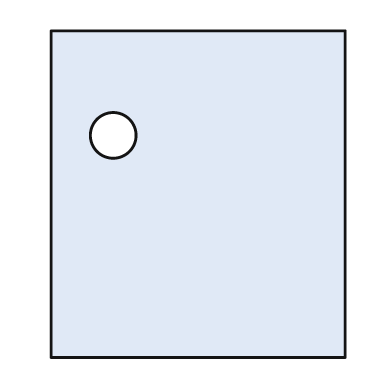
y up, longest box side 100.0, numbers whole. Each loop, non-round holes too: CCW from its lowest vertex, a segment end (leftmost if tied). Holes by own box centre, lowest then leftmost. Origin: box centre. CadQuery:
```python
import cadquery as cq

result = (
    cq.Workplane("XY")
    .moveTo(-45.0, -50.0)
    .lineTo(45.0, -50.0)
    .lineTo(45.0, 50.0)
    .lineTo(-45.0, 50.0)
    .close()
    .moveTo(-26.0, 18.0)
    .circle(7.0)
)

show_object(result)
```